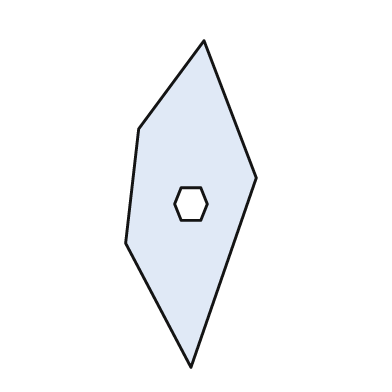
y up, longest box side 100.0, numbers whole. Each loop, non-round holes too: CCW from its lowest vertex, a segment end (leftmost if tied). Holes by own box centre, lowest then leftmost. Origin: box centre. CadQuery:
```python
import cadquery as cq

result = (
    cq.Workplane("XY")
    .moveTo(0.0, -50.0)
    .lineTo(20.0, 8.0)
    .lineTo(4.0, 50.0)
    .lineTo(-16.0, 23.0)
    .lineTo(-20.0, -12.0)
    .close()
    .moveTo(-3.0, -5.0)
    .lineTo(3.0, -5.0)
    .lineTo(5.0, 0.0)
    .lineTo(3.0, 5.0)
    .lineTo(-3.0, 5.0)
    .lineTo(-5.0, 0.0)
    .close()
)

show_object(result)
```